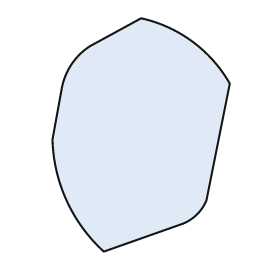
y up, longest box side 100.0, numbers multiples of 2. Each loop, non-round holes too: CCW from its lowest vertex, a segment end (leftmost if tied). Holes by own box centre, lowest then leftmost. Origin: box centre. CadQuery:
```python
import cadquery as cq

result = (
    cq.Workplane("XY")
    .moveTo(-16.0, -50.0)
    .lineTo(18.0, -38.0)
    .threePointArc((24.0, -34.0), (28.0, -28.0))
    .lineTo(38.0, 22.0)
    .threePointArc((22.0, 40.0), (0.0, 50.0))
    .lineTo(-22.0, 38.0)
    .threePointArc((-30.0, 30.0), (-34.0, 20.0))
    .lineTo(-38.0, -2.0)
    .threePointArc((-32.0, -28.0), (-16.0, -50.0))
    .close()
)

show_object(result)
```